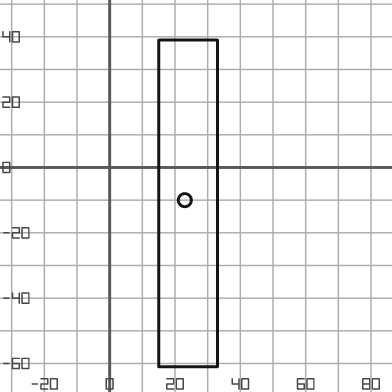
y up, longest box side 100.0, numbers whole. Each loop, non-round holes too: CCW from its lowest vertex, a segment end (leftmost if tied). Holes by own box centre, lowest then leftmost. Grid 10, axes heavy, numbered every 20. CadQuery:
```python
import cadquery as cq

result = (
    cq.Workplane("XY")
    .moveTo(15.0, -61.0)
    .lineTo(33.0, -61.0)
    .lineTo(33.0, 39.0)
    .lineTo(15.0, 39.0)
    .close()
    .moveTo(23.0, -10.0)
    .circle(2.0)
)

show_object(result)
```